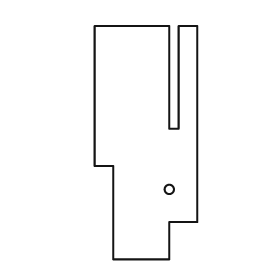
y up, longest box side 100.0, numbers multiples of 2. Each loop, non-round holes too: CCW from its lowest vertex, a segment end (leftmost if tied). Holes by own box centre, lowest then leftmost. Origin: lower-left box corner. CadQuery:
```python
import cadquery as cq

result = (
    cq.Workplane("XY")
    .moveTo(8.0, 0.0)
    .lineTo(32.0, 0.0)
    .lineTo(32.0, 16.0)
    .lineTo(44.0, 16.0)
    .lineTo(44.0, 100.0)
    .lineTo(36.0, 100.0)
    .lineTo(36.0, 56.0)
    .lineTo(32.0, 56.0)
    .lineTo(32.0, 100.0)
    .lineTo(0.0, 100.0)
    .lineTo(0.0, 40.0)
    .lineTo(8.0, 40.0)
    .close()
    .moveTo(32.0, 30.0)
    .circle(2.0)
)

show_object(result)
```